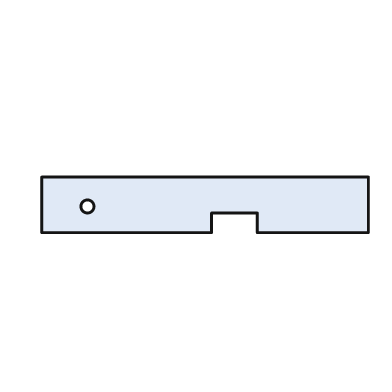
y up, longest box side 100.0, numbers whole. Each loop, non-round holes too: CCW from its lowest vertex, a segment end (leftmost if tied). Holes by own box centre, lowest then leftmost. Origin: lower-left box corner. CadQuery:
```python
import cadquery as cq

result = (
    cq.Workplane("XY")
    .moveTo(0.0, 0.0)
    .lineTo(52.0, 0.0)
    .lineTo(52.0, 6.0)
    .lineTo(66.0, 6.0)
    .lineTo(66.0, 0.0)
    .lineTo(100.0, 0.0)
    .lineTo(100.0, 17.0)
    .lineTo(0.0, 17.0)
    .close()
    .moveTo(14.0, 8.0)
    .circle(2.0)
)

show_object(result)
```